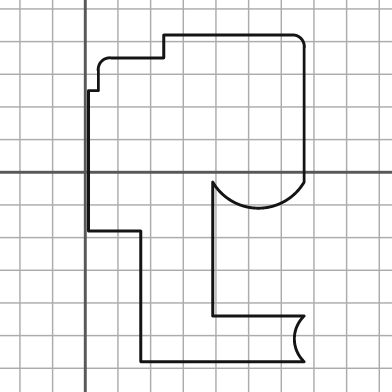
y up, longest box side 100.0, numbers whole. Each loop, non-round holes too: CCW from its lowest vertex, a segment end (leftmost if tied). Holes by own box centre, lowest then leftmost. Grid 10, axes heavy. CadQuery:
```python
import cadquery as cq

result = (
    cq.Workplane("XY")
    .moveTo(17.0, -58.0)
    .lineTo(67.0, -58.0)
    .threePointArc((64.0, -51.0), (67.0, -44.0))
    .lineTo(39.0, -44.0)
    .lineTo(39.0, -3.0)
    .threePointArc((53.0, -11.0), (67.0, -3.0))
    .lineTo(67.0, 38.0)
    .threePointArc((66.0, 41.0), (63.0, 42.0))
    .lineTo(24.0, 42.0)
    .lineTo(24.0, 35.0)
    .lineTo(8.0, 35.0)
    .threePointArc((5.0, 34.0), (4.0, 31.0))
    .lineTo(4.0, 25.0)
    .lineTo(1.0, 25.0)
    .lineTo(1.0, -18.0)
    .lineTo(17.0, -18.0)
    .close()
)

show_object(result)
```